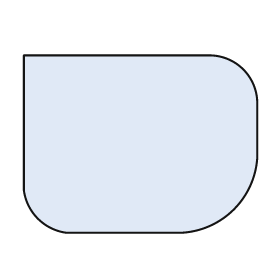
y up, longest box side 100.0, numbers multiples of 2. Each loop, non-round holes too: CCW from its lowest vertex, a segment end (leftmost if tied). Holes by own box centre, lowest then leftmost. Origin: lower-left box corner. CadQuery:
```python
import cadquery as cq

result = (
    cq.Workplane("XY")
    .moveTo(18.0, 0.0)
    .lineTo(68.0, 0.0)
    .threePointArc((90.0, 10.0), (100.0, 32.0))
    .lineTo(100.0, 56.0)
    .threePointArc((94.0, 70.0), (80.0, 76.0))
    .lineTo(0.0, 76.0)
    .lineTo(0.0, 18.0)
    .threePointArc((6.0, 6.0), (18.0, 0.0))
    .close()
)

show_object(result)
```